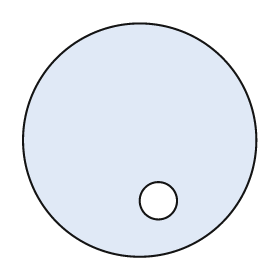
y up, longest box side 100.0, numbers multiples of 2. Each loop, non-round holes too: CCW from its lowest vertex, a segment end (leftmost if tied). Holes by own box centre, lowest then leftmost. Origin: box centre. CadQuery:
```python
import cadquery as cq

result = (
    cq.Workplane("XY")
    .moveTo(0.0, 0.0)
    .circle(50.0)
    .moveTo(8.0, -26.0)
    .circle(8.0)
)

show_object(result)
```